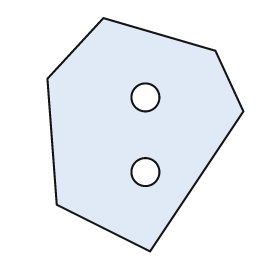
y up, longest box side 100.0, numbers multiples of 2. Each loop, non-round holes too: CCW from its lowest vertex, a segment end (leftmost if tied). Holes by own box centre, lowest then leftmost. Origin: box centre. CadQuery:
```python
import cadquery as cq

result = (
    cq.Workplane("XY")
    .moveTo(2.0, -50.0)
    .lineTo(42.0, 10.0)
    .lineTo(30.0, 36.0)
    .lineTo(-18.0, 50.0)
    .lineTo(-42.0, 24.0)
    .lineTo(-38.0, -30.0)
    .close()
    .moveTo(0.0, -16.0)
    .circle(6.0)
    .moveTo(0.0, 16.0)
    .circle(6.0)
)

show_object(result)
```